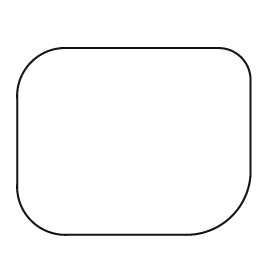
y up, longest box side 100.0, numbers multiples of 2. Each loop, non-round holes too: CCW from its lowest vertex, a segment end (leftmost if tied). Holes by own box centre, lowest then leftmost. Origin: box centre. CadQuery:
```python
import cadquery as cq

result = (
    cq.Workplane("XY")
    .moveTo(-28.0, -40.0)
    .lineTo(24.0, -40.0)
    .threePointArc((42.0, -32.0), (50.0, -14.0))
    .lineTo(50.0, 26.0)
    .threePointArc((46.0, 36.0), (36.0, 40.0))
    .lineTo(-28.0, 40.0)
    .threePointArc((-44.0, 34.0), (-50.0, 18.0))
    .lineTo(-50.0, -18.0)
    .threePointArc((-44.0, -34.0), (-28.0, -40.0))
    .close()
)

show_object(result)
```